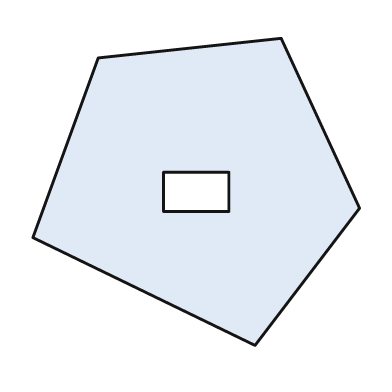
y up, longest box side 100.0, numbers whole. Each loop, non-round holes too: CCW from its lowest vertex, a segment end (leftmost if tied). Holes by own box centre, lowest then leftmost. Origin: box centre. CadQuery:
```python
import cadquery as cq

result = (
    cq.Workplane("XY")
    .moveTo(18.0, -47.0)
    .lineTo(50.0, -5.0)
    .lineTo(26.0, 47.0)
    .lineTo(-30.0, 41.0)
    .lineTo(-50.0, -14.0)
    .close()
    .moveTo(-10.0, -6.0)
    .lineTo(10.0, -6.0)
    .lineTo(10.0, 6.0)
    .lineTo(-10.0, 6.0)
    .close()
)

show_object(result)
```